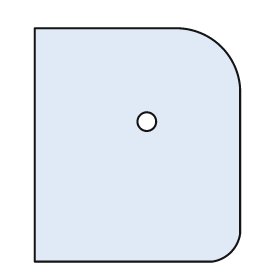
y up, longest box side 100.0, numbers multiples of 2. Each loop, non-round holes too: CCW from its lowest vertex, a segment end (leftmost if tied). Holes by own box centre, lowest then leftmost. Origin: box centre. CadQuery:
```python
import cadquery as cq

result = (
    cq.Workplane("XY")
    .moveTo(-44.0, -50.0)
    .lineTo(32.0, -50.0)
    .threePointArc((40.0, -46.0), (44.0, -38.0))
    .lineTo(44.0, 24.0)
    .threePointArc((36.0, 42.0), (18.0, 50.0))
    .lineTo(-44.0, 50.0)
    .close()
    .moveTo(4.0, 10.0)
    .circle(4.0)
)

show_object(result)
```